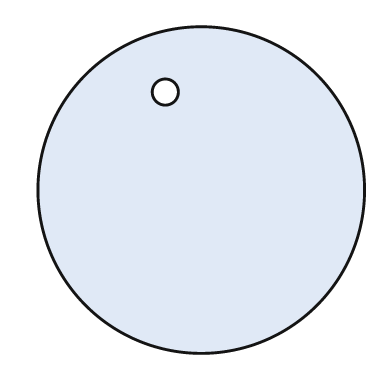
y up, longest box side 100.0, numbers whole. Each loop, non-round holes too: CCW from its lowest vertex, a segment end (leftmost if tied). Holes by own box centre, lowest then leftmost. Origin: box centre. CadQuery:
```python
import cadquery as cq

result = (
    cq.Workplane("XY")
    .moveTo(0.0, 0.0)
    .circle(50.0)
    .moveTo(-11.0, 30.0)
    .circle(4.0)
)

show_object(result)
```